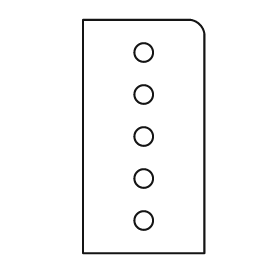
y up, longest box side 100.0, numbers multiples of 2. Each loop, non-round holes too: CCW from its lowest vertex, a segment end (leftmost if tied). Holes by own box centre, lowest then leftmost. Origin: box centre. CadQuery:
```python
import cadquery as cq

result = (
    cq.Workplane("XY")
    .moveTo(-26.0, -50.0)
    .lineTo(26.0, -50.0)
    .lineTo(26.0, 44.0)
    .threePointArc((24.0, 48.0), (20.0, 50.0))
    .lineTo(-26.0, 50.0)
    .close()
    .moveTo(0.0, -36.0)
    .circle(4.0)
    .moveTo(0.0, -18.0)
    .circle(4.0)
    .moveTo(0.0, 0.0)
    .circle(4.0)
    .moveTo(0.0, 18.0)
    .circle(4.0)
    .moveTo(0.0, 36.0)
    .circle(4.0)
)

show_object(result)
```